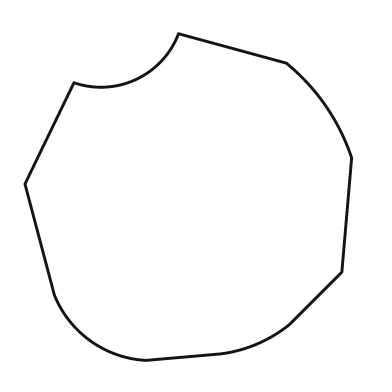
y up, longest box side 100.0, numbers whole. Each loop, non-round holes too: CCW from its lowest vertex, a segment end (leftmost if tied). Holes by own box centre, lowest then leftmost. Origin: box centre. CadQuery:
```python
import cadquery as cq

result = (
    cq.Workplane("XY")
    .moveTo(-13.0, -50.0)
    .lineTo(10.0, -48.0)
    .threePointArc((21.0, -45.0), (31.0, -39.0))
    .lineTo(47.0, -23.0)
    .lineTo(50.0, 12.0)
    .threePointArc((42.0, 28.0), (30.0, 41.0))
    .lineTo(-3.0, 50.0)
    .threePointArc((-16.0, 36.0), (-35.0, 35.0))
    .lineTo(-50.0, 4.0)
    .lineTo(-41.0, -30.0)
    .threePointArc((-30.0, -44.0), (-13.0, -50.0))
    .close()
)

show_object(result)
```